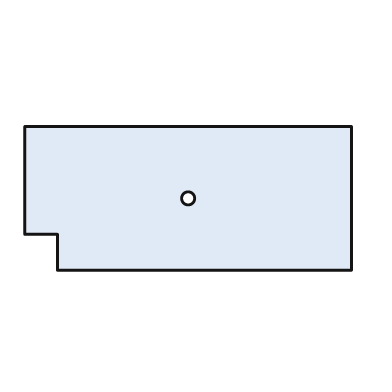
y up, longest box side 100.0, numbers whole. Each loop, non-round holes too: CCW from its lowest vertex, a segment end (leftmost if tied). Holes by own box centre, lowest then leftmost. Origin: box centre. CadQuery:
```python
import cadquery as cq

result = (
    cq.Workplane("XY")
    .moveTo(-40.0, -22.0)
    .lineTo(50.0, -22.0)
    .lineTo(50.0, 22.0)
    .lineTo(-50.0, 22.0)
    .lineTo(-50.0, -11.0)
    .lineTo(-40.0, -11.0)
    .close()
    .moveTo(0.0, 0.0)
    .circle(2.0)
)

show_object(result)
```